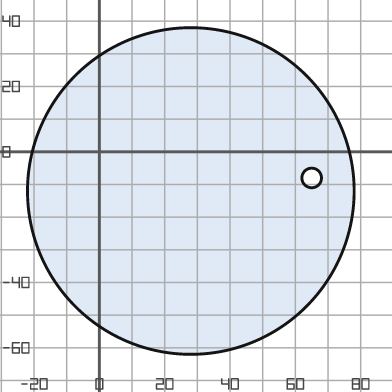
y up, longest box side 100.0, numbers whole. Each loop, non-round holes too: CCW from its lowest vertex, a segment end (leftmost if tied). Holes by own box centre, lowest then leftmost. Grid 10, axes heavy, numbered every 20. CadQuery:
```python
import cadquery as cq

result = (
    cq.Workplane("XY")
    .moveTo(28.0, -12.0)
    .circle(50.0)
    .moveTo(65.0, -8.0)
    .circle(3.0)
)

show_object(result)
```